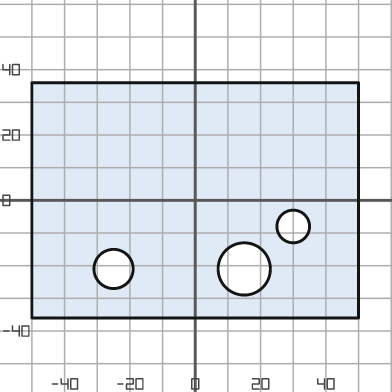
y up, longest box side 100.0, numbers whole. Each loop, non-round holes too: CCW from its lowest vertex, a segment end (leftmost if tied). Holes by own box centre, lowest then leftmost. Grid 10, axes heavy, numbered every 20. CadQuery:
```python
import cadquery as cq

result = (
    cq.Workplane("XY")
    .moveTo(-50.0, -36.0)
    .lineTo(50.0, -36.0)
    .lineTo(50.0, 36.0)
    .lineTo(-50.0, 36.0)
    .close()
    .moveTo(-25.0, -21.0)
    .circle(6.0)
    .moveTo(15.0, -21.0)
    .circle(8.0)
    .moveTo(30.0, -8.0)
    .circle(5.0)
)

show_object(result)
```